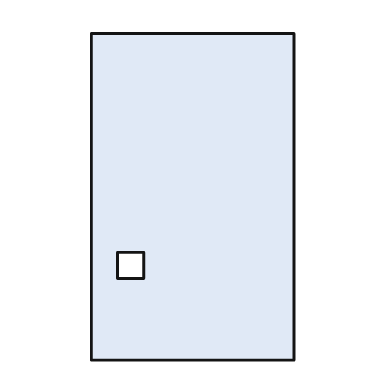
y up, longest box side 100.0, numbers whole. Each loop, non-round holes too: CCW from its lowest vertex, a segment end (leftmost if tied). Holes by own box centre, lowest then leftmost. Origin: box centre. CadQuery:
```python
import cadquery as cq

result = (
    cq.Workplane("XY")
    .moveTo(-31.0, -50.0)
    .lineTo(31.0, -50.0)
    .lineTo(31.0, 50.0)
    .lineTo(-31.0, 50.0)
    .close()
    .moveTo(-23.0, -25.0)
    .lineTo(-15.0, -25.0)
    .lineTo(-15.0, -17.0)
    .lineTo(-23.0, -17.0)
    .close()
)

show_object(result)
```